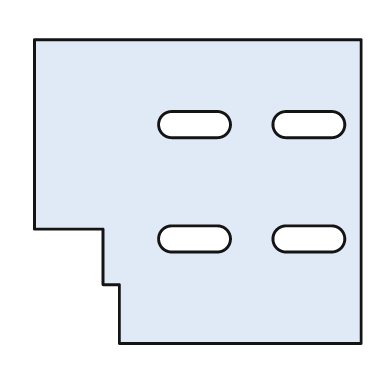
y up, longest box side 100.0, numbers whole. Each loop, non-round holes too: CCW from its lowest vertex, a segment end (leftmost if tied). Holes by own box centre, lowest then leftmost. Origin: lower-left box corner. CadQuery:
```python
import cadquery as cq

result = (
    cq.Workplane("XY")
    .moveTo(26.0, 0.0)
    .lineTo(100.0, 0.0)
    .lineTo(100.0, 93.0)
    .lineTo(0.0, 93.0)
    .lineTo(0.0, 35.0)
    .lineTo(21.0, 35.0)
    .lineTo(21.0, 18.0)
    .lineTo(26.0, 18.0)
    .close()
    .moveTo(42.0, 28.0)
    .lineTo(56.0, 28.0)
    .threePointArc((60.0, 32.0), (56.0, 36.0))
    .lineTo(42.0, 36.0)
    .threePointArc((38.0, 32.0), (42.0, 28.0))
    .close()
    .moveTo(77.0, 28.0)
    .lineTo(91.0, 28.0)
    .threePointArc((95.0, 32.0), (91.0, 36.0))
    .lineTo(77.0, 36.0)
    .threePointArc((73.0, 32.0), (77.0, 28.0))
    .close()
    .moveTo(42.0, 63.0)
    .lineTo(56.0, 63.0)
    .threePointArc((60.0, 67.0), (56.0, 71.0))
    .lineTo(42.0, 71.0)
    .threePointArc((38.0, 67.0), (42.0, 63.0))
    .close()
    .moveTo(77.0, 63.0)
    .lineTo(91.0, 63.0)
    .threePointArc((95.0, 67.0), (91.0, 71.0))
    .lineTo(77.0, 71.0)
    .threePointArc((73.0, 67.0), (77.0, 63.0))
    .close()
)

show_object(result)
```